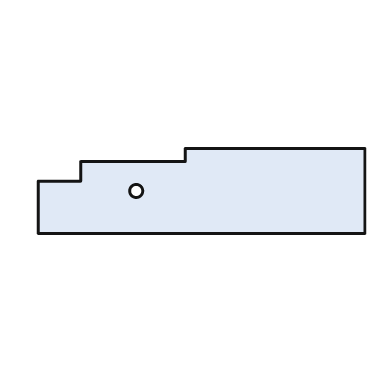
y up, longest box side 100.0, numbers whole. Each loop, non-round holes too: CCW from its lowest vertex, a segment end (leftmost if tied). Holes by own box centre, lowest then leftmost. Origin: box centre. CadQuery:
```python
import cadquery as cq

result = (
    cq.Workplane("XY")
    .moveTo(-50.0, -13.0)
    .lineTo(50.0, -13.0)
    .lineTo(50.0, 13.0)
    .lineTo(-5.0, 13.0)
    .lineTo(-5.0, 9.0)
    .lineTo(-37.0, 9.0)
    .lineTo(-37.0, 3.0)
    .lineTo(-50.0, 3.0)
    .close()
    .moveTo(-20.0, 0.0)
    .circle(2.0)
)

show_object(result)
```